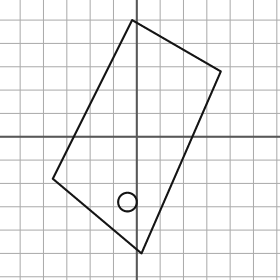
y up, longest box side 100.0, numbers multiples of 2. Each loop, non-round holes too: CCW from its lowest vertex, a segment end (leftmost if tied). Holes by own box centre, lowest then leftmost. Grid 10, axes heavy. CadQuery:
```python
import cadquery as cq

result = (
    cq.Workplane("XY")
    .moveTo(2.0, -50.0)
    .lineTo(36.0, 28.0)
    .lineTo(-2.0, 50.0)
    .lineTo(-36.0, -18.0)
    .close()
    .moveTo(-4.0, -28.0)
    .circle(4.0)
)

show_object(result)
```